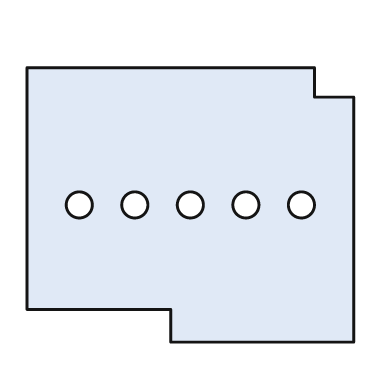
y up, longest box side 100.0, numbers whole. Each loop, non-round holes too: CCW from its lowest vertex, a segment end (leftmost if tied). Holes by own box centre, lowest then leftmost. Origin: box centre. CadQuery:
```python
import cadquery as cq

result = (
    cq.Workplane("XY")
    .moveTo(-6.0, -42.0)
    .lineTo(50.0, -42.0)
    .lineTo(50.0, 33.0)
    .lineTo(38.0, 33.0)
    .lineTo(38.0, 42.0)
    .lineTo(-50.0, 42.0)
    .lineTo(-50.0, -32.0)
    .lineTo(-6.0, -32.0)
    .close()
    .moveTo(-34.0, 0.0)
    .circle(4.0)
    .moveTo(-17.0, 0.0)
    .circle(4.0)
    .moveTo(0.0, 0.0)
    .circle(4.0)
    .moveTo(17.0, 0.0)
    .circle(4.0)
    .moveTo(34.0, 0.0)
    .circle(4.0)
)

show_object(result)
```